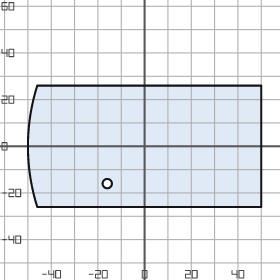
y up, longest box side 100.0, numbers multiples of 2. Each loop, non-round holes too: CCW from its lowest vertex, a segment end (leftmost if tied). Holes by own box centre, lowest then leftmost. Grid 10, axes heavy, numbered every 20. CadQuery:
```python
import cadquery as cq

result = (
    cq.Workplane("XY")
    .moveTo(-46.0, -26.0)
    .lineTo(50.0, -26.0)
    .lineTo(50.0, 26.0)
    .lineTo(-46.0, 26.0)
    .threePointArc((-50.0, 0.0), (-46.0, -26.0))
    .close()
    .moveTo(-16.0, -16.0)
    .circle(2.0)
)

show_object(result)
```